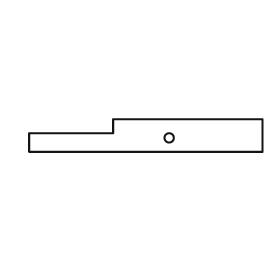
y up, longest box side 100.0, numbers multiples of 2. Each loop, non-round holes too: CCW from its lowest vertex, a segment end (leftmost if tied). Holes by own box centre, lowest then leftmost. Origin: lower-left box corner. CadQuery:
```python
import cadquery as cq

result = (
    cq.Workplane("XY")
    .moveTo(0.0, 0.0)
    .lineTo(100.0, 0.0)
    .lineTo(100.0, 14.0)
    .lineTo(36.0, 14.0)
    .lineTo(36.0, 8.0)
    .lineTo(0.0, 8.0)
    .close()
    .moveTo(60.0, 6.0)
    .circle(2.0)
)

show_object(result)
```